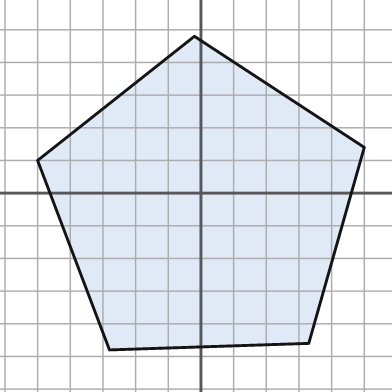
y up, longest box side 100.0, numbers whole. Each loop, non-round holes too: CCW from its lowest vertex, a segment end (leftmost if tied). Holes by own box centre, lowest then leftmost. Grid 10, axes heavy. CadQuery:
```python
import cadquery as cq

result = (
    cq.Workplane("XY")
    .moveTo(-28.0, -48.0)
    .lineTo(33.0, -46.0)
    .lineTo(50.0, 14.0)
    .lineTo(-2.0, 48.0)
    .lineTo(-50.0, 10.0)
    .close()
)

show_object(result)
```